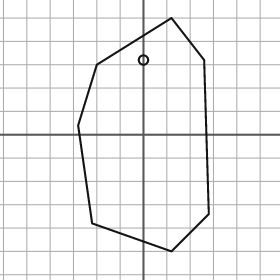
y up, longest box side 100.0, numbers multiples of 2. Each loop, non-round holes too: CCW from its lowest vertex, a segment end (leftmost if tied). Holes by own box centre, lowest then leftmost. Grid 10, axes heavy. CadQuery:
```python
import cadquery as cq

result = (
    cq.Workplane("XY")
    .moveTo(12.0, -50.0)
    .lineTo(28.0, -34.0)
    .lineTo(26.0, 32.0)
    .lineTo(12.0, 50.0)
    .lineTo(-20.0, 30.0)
    .lineTo(-28.0, 4.0)
    .lineTo(-22.0, -38.0)
    .close()
    .moveTo(0.0, 32.0)
    .circle(2.0)
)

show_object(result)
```